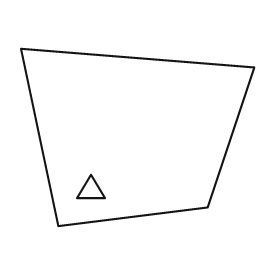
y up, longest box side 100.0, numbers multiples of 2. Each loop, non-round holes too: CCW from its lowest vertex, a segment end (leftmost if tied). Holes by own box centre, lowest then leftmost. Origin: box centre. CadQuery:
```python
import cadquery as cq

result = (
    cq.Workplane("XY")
    .moveTo(-34.0, -38.0)
    .lineTo(30.0, -30.0)
    .lineTo(50.0, 30.0)
    .lineTo(-50.0, 38.0)
    .close()
    .moveTo(-26.0, -26.0)
    .lineTo(-14.0, -26.0)
    .lineTo(-20.0, -16.0)
    .close()
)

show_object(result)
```